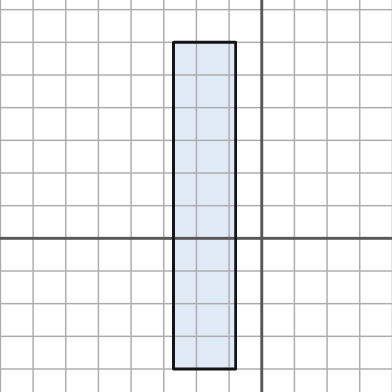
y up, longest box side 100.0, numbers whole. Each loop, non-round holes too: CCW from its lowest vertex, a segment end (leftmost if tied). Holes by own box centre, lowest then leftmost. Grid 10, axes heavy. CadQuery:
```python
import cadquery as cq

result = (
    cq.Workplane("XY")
    .moveTo(-27.0, -40.0)
    .lineTo(-8.0, -40.0)
    .lineTo(-8.0, 60.0)
    .lineTo(-27.0, 60.0)
    .close()
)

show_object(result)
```